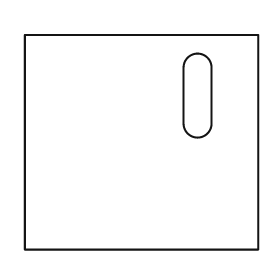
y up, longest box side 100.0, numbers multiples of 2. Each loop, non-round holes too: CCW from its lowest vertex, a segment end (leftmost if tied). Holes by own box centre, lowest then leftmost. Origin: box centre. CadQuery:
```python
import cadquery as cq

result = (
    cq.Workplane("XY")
    .moveTo(-50.0, -46.0)
    .lineTo(50.0, -46.0)
    .lineTo(50.0, 46.0)
    .lineTo(-50.0, 46.0)
    .close()
    .moveTo(18.0, 8.0)
    .threePointArc((24.0, 2.0), (30.0, 8.0))
    .lineTo(30.0, 32.0)
    .threePointArc((24.0, 38.0), (18.0, 32.0))
    .close()
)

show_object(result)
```